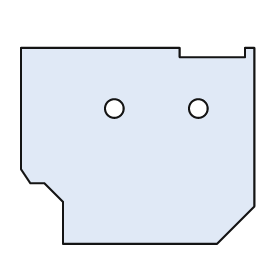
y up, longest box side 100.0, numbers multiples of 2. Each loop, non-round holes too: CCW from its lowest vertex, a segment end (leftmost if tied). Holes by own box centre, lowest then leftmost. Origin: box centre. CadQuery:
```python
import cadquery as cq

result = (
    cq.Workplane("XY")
    .moveTo(-32.0, -42.0)
    .lineTo(34.0, -42.0)
    .lineTo(50.0, -26.0)
    .lineTo(50.0, 42.0)
    .lineTo(46.0, 42.0)
    .lineTo(46.0, 38.0)
    .lineTo(18.0, 38.0)
    .lineTo(18.0, 42.0)
    .lineTo(-50.0, 42.0)
    .lineTo(-50.0, -10.0)
    .lineTo(-46.0, -16.0)
    .lineTo(-40.0, -16.0)
    .lineTo(-32.0, -24.0)
    .close()
    .moveTo(-10.0, 16.0)
    .circle(4.0)
    .moveTo(26.0, 16.0)
    .circle(4.0)
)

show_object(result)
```